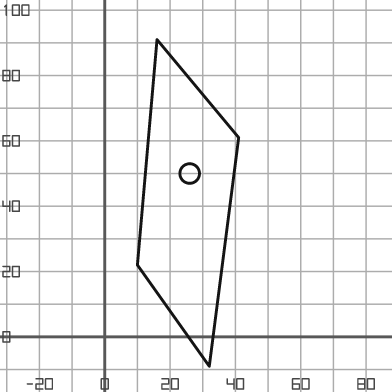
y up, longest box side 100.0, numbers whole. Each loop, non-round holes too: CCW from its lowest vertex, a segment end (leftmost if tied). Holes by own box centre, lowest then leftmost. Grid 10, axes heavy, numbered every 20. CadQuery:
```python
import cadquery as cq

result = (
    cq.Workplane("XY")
    .moveTo(32.0, -9.0)
    .lineTo(41.0, 61.0)
    .lineTo(16.0, 91.0)
    .lineTo(10.0, 22.0)
    .close()
    .moveTo(26.0, 50.0)
    .circle(3.0)
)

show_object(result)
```